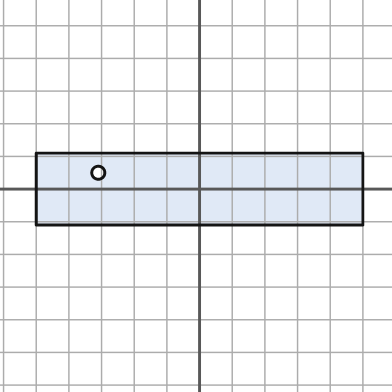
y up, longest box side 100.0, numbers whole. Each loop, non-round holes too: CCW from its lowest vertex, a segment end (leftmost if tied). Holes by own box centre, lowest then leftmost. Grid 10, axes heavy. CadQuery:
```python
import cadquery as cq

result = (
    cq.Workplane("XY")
    .moveTo(-50.0, -11.0)
    .lineTo(50.0, -11.0)
    .lineTo(50.0, 11.0)
    .lineTo(-50.0, 11.0)
    .close()
    .moveTo(-31.0, 5.0)
    .circle(2.0)
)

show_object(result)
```